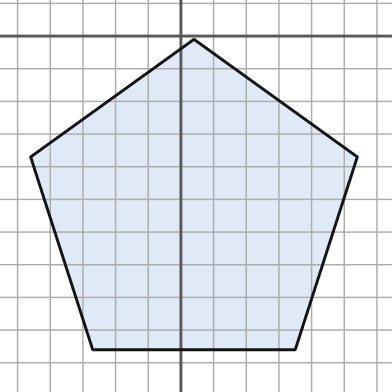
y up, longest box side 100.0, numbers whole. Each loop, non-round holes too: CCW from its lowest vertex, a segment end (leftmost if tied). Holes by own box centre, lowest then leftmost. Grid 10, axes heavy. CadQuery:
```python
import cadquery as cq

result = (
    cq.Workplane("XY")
    .moveTo(-27.0, -96.0)
    .lineTo(35.0, -96.0)
    .lineTo(54.0, -37.0)
    .lineTo(4.0, -1.0)
    .lineTo(-46.0, -37.0)
    .close()
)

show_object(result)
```